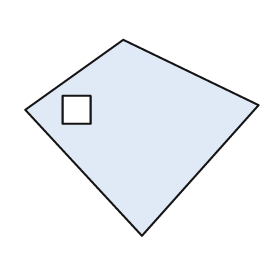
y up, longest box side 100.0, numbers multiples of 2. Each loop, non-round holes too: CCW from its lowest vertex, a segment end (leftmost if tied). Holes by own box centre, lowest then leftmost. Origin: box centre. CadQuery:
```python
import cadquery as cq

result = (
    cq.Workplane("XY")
    .moveTo(0.0, -42.0)
    .lineTo(50.0, 14.0)
    .lineTo(-8.0, 42.0)
    .lineTo(-50.0, 12.0)
    .close()
    .moveTo(-34.0, 6.0)
    .lineTo(-22.0, 6.0)
    .lineTo(-22.0, 18.0)
    .lineTo(-34.0, 18.0)
    .close()
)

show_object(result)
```